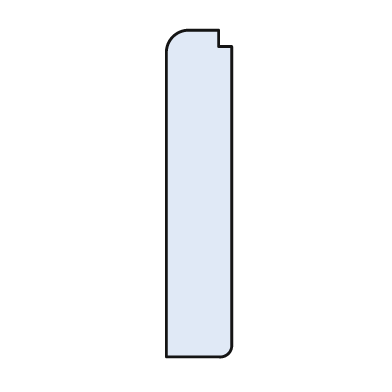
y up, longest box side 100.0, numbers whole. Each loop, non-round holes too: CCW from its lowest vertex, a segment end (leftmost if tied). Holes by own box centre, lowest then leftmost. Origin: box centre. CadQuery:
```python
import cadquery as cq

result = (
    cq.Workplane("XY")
    .moveTo(-10.0, -50.0)
    .lineTo(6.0, -50.0)
    .threePointArc((9.0, -49.0), (10.0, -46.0))
    .lineTo(10.0, 45.0)
    .lineTo(6.0, 45.0)
    .lineTo(6.0, 50.0)
    .lineTo(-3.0, 50.0)
    .threePointArc((-8.0, 48.0), (-10.0, 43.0))
    .close()
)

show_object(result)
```